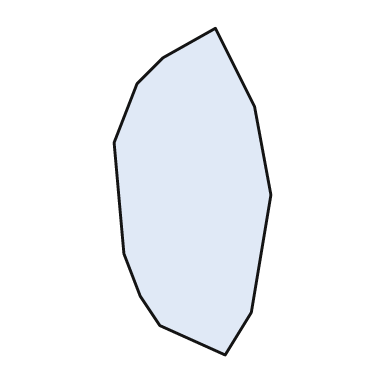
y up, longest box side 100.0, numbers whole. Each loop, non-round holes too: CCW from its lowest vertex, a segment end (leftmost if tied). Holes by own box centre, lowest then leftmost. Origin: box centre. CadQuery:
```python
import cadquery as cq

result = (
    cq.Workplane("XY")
    .moveTo(10.0, -50.0)
    .lineTo(18.0, -37.0)
    .lineTo(24.0, -1.0)
    .lineTo(19.0, 26.0)
    .lineTo(7.0, 50.0)
    .lineTo(-9.0, 41.0)
    .lineTo(-17.0, 33.0)
    .lineTo(-24.0, 15.0)
    .lineTo(-21.0, -19.0)
    .lineTo(-16.0, -32.0)
    .lineTo(-10.0, -41.0)
    .close()
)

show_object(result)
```